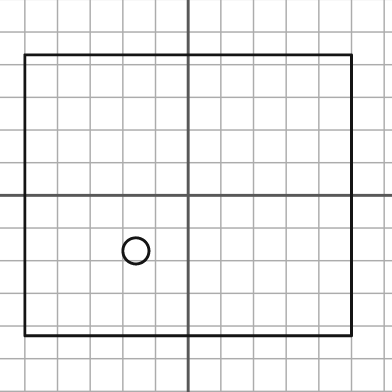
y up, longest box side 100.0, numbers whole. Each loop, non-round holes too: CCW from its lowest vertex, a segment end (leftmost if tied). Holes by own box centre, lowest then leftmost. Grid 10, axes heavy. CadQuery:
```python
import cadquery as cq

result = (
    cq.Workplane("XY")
    .moveTo(-50.0, -43.0)
    .lineTo(50.0, -43.0)
    .lineTo(50.0, 43.0)
    .lineTo(-50.0, 43.0)
    .close()
    .moveTo(-16.0, -17.0)
    .circle(4.0)
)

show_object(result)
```